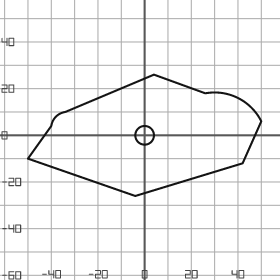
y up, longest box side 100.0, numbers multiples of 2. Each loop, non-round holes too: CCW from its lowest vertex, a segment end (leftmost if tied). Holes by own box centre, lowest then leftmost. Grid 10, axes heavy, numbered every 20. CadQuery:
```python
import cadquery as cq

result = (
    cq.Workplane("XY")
    .moveTo(-4.0, -26.0)
    .lineTo(42.0, -12.0)
    .lineTo(50.0, 6.0)
    .threePointArc((40.0, 16.0), (26.0, 18.0))
    .lineTo(4.0, 26.0)
    .lineTo(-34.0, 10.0)
    .threePointArc((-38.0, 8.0), (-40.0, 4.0))
    .lineTo(-50.0, -10.0)
    .close()
    .moveTo(0.0, 0.0)
    .circle(4.0)
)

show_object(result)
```